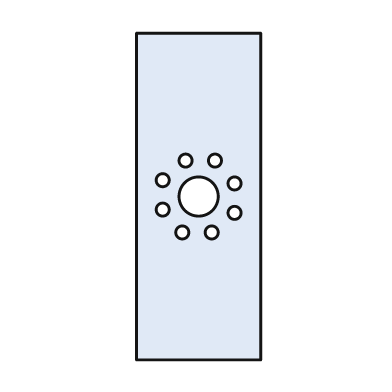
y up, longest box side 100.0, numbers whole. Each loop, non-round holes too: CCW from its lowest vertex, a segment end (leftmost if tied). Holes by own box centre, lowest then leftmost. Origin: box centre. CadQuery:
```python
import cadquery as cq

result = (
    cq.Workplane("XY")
    .moveTo(-19.0, -50.0)
    .lineTo(19.0, -50.0)
    .lineTo(19.0, 50.0)
    .lineTo(-19.0, 50.0)
    .close()
    .moveTo(-5.0, -11.0)
    .circle(2.0)
    .moveTo(4.0, -11.0)
    .circle(2.0)
    .moveTo(11.0, -5.0)
    .circle(2.0)
    .moveTo(-11.0, -4.0)
    .circle(2.0)
    .moveTo(0.0, 0.0)
    .circle(6.0)
    .moveTo(11.0, 4.0)
    .circle(2.0)
    .moveTo(-11.0, 5.0)
    .circle(2.0)
    .moveTo(-4.0, 11.0)
    .circle(2.0)
    .moveTo(5.0, 11.0)
    .circle(2.0)
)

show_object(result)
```